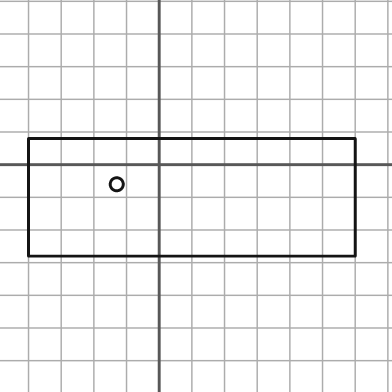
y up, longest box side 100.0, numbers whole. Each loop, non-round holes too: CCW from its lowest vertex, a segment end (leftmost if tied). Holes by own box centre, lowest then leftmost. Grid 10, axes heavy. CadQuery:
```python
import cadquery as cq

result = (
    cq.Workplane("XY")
    .moveTo(-40.0, -28.0)
    .lineTo(60.0, -28.0)
    .lineTo(60.0, 8.0)
    .lineTo(-40.0, 8.0)
    .close()
    .moveTo(-13.0, -6.0)
    .circle(2.0)
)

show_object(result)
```